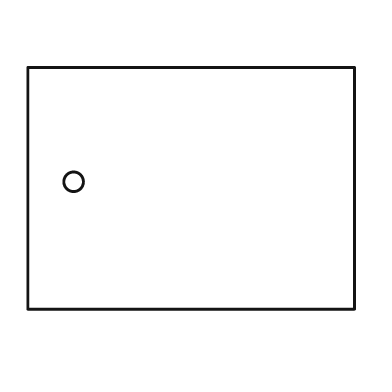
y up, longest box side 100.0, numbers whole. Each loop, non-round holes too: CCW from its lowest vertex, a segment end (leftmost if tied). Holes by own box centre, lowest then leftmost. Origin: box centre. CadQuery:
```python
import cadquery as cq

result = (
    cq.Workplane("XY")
    .moveTo(-50.0, -37.0)
    .lineTo(50.0, -37.0)
    .lineTo(50.0, 37.0)
    .lineTo(-50.0, 37.0)
    .close()
    .moveTo(-36.0, 2.0)
    .circle(3.0)
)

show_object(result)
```